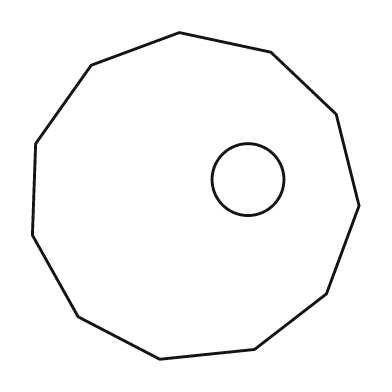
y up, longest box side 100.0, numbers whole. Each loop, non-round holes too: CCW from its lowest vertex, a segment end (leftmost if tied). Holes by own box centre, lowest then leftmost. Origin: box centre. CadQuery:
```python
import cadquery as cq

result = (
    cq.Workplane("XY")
    .moveTo(-11.0, -50.0)
    .lineTo(18.0, -47.0)
    .lineTo(40.0, -30.0)
    .lineTo(50.0, -3.0)
    .lineTo(43.0, 25.0)
    .lineTo(23.0, 44.0)
    .lineTo(-5.0, 50.0)
    .lineTo(-32.0, 40.0)
    .lineTo(-49.0, 16.0)
    .lineTo(-50.0, -12.0)
    .lineTo(-36.0, -37.0)
    .close()
    .moveTo(16.0, 5.0)
    .circle(11.0)
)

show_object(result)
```